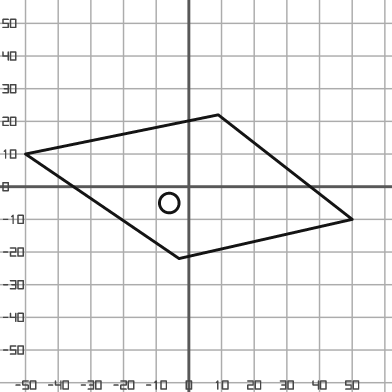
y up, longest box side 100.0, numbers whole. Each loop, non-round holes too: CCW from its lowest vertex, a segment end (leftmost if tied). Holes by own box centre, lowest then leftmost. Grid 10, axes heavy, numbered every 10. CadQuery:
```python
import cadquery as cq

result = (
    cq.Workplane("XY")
    .moveTo(-3.0, -22.0)
    .lineTo(50.0, -10.0)
    .lineTo(9.0, 22.0)
    .lineTo(-50.0, 10.0)
    .close()
    .moveTo(-6.0, -5.0)
    .circle(3.0)
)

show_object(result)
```